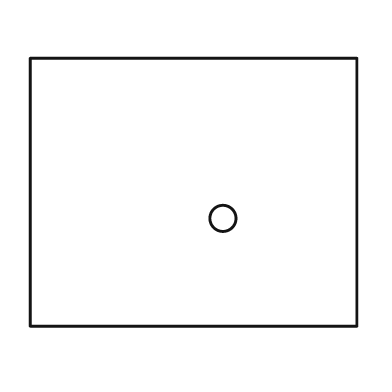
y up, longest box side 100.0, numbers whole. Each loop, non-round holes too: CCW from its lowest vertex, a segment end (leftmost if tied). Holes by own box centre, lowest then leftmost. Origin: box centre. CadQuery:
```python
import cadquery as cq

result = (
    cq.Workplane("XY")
    .moveTo(-50.0, -41.0)
    .lineTo(50.0, -41.0)
    .lineTo(50.0, 41.0)
    .lineTo(-50.0, 41.0)
    .close()
    .moveTo(9.0, -8.0)
    .circle(4.0)
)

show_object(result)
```